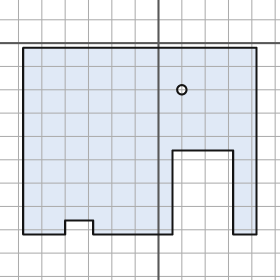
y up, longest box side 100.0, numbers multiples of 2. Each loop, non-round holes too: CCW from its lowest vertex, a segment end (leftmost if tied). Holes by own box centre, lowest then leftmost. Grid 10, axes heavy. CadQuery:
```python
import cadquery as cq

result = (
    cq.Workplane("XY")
    .moveTo(-58.0, -82.0)
    .lineTo(-40.0, -82.0)
    .lineTo(-40.0, -76.0)
    .lineTo(-28.0, -76.0)
    .lineTo(-28.0, -82.0)
    .lineTo(6.0, -82.0)
    .lineTo(6.0, -46.0)
    .lineTo(32.0, -46.0)
    .lineTo(32.0, -82.0)
    .lineTo(42.0, -82.0)
    .lineTo(42.0, -2.0)
    .lineTo(-58.0, -2.0)
    .close()
    .moveTo(10.0, -20.0)
    .circle(2.0)
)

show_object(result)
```